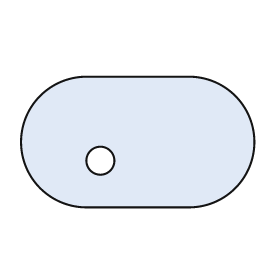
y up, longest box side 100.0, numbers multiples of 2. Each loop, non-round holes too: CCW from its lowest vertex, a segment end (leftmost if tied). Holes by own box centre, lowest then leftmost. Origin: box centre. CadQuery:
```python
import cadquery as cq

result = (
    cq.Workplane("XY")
    .moveTo(-22.0, -28.0)
    .lineTo(22.0, -28.0)
    .threePointArc((50.0, 0.0), (22.0, 28.0))
    .lineTo(-22.0, 28.0)
    .threePointArc((-50.0, 0.0), (-22.0, -28.0))
    .close()
    .moveTo(-16.0, -8.0)
    .circle(6.0)
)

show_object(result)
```